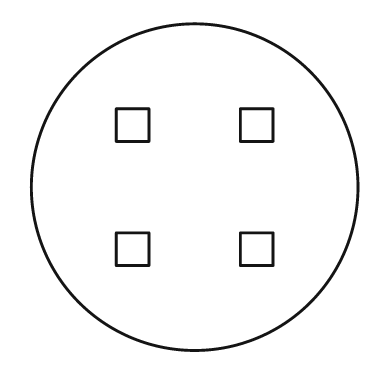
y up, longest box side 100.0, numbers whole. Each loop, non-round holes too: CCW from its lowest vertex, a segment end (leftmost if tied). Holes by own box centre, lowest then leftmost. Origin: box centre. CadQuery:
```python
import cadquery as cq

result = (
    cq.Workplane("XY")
    .moveTo(0.0, 0.0)
    .circle(50.0)
    .moveTo(-24.0, -24.0)
    .lineTo(-14.0, -24.0)
    .lineTo(-14.0, -14.0)
    .lineTo(-24.0, -14.0)
    .close()
    .moveTo(14.0, -24.0)
    .lineTo(24.0, -24.0)
    .lineTo(24.0, -14.0)
    .lineTo(14.0, -14.0)
    .close()
    .moveTo(-24.0, 14.0)
    .lineTo(-14.0, 14.0)
    .lineTo(-14.0, 24.0)
    .lineTo(-24.0, 24.0)
    .close()
    .moveTo(14.0, 14.0)
    .lineTo(24.0, 14.0)
    .lineTo(24.0, 24.0)
    .lineTo(14.0, 24.0)
    .close()
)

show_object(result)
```